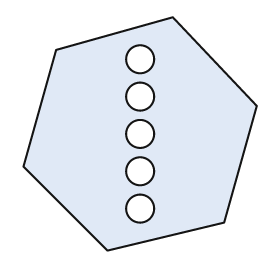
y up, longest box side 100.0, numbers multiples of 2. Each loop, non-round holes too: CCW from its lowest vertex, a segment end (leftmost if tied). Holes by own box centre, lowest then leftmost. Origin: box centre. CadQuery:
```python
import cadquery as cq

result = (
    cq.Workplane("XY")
    .moveTo(-14.0, -50.0)
    .lineTo(36.0, -38.0)
    .lineTo(50.0, 12.0)
    .lineTo(14.0, 50.0)
    .lineTo(-36.0, 36.0)
    .lineTo(-50.0, -14.0)
    .close()
    .moveTo(0.0, -32.0)
    .circle(6.0)
    .moveTo(0.0, -16.0)
    .circle(6.0)
    .moveTo(0.0, 0.0)
    .circle(6.0)
    .moveTo(0.0, 16.0)
    .circle(6.0)
    .moveTo(0.0, 32.0)
    .circle(6.0)
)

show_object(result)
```